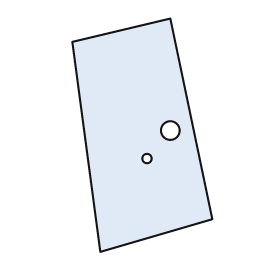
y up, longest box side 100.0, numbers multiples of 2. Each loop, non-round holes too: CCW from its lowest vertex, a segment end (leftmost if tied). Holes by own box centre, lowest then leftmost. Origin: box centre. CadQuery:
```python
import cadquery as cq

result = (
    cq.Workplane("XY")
    .moveTo(-18.0, -50.0)
    .lineTo(30.0, -36.0)
    .lineTo(12.0, 50.0)
    .lineTo(-30.0, 40.0)
    .close()
    .moveTo(2.0, -10.0)
    .circle(2.0)
    .moveTo(12.0, 2.0)
    .circle(4.0)
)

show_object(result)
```